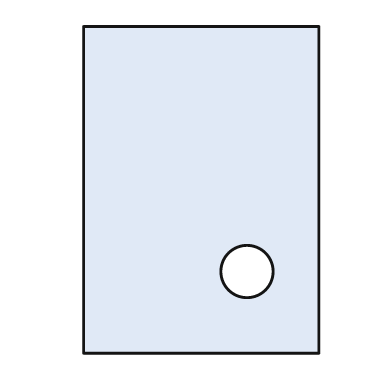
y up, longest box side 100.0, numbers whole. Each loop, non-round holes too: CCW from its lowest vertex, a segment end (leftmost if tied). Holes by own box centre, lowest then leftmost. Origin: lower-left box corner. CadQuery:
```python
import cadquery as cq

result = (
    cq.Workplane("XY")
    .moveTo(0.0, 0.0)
    .lineTo(72.0, 0.0)
    .lineTo(72.0, 100.0)
    .lineTo(0.0, 100.0)
    .close()
    .moveTo(50.0, 25.0)
    .circle(8.0)
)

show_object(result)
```